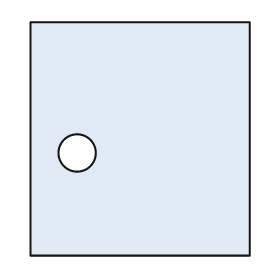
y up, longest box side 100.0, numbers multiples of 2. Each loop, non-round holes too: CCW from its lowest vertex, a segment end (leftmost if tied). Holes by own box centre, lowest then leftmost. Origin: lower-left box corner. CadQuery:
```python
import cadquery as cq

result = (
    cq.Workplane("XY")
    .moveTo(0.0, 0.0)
    .lineTo(94.0, 0.0)
    .lineTo(94.0, 100.0)
    .lineTo(0.0, 100.0)
    .close()
    .moveTo(20.0, 44.0)
    .circle(8.0)
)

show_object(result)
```